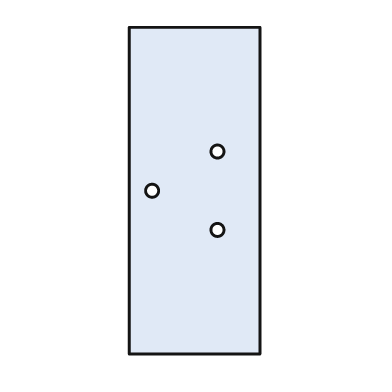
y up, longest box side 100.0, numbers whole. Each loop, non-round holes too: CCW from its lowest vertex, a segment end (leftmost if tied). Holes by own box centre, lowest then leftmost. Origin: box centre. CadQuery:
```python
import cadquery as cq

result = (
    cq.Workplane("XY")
    .moveTo(-20.0, -50.0)
    .lineTo(20.0, -50.0)
    .lineTo(20.0, 50.0)
    .lineTo(-20.0, 50.0)
    .close()
    .moveTo(7.0, -12.0)
    .circle(2.0)
    .moveTo(-13.0, 0.0)
    .circle(2.0)
    .moveTo(7.0, 12.0)
    .circle(2.0)
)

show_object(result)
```